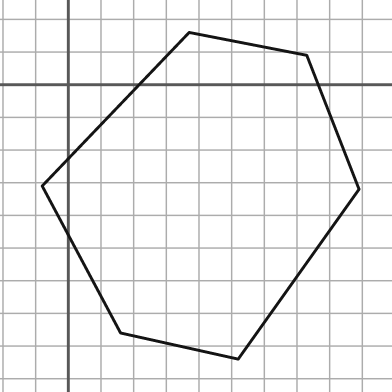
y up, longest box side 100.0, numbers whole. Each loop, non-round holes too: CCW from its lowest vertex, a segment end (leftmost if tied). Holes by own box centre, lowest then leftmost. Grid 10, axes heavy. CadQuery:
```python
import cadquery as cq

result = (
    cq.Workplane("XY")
    .moveTo(52.0, -84.0)
    .lineTo(89.0, -32.0)
    .lineTo(73.0, 9.0)
    .lineTo(37.0, 16.0)
    .lineTo(-8.0, -31.0)
    .lineTo(16.0, -76.0)
    .close()
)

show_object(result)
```